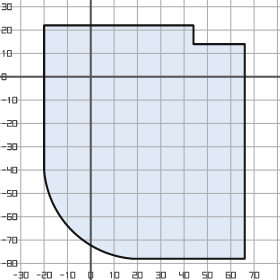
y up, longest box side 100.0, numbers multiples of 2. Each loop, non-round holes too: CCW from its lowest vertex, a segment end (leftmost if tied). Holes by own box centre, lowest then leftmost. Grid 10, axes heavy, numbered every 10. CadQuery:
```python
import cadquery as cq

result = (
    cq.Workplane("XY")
    .moveTo(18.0, -78.0)
    .lineTo(66.0, -78.0)
    .lineTo(66.0, 14.0)
    .lineTo(44.0, 14.0)
    .lineTo(44.0, 22.0)
    .lineTo(-20.0, 22.0)
    .lineTo(-20.0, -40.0)
    .threePointArc((-8.0, -66.0), (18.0, -78.0))
    .close()
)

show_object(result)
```